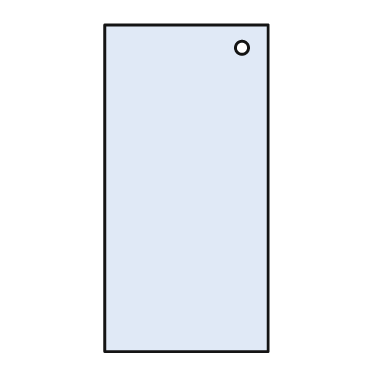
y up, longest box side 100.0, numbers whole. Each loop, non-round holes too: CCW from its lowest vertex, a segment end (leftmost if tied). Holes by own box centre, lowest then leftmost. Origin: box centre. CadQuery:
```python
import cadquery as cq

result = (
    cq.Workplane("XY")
    .moveTo(-25.0, -50.0)
    .lineTo(25.0, -50.0)
    .lineTo(25.0, 50.0)
    .lineTo(-25.0, 50.0)
    .close()
    .moveTo(17.0, 43.0)
    .circle(2.0)
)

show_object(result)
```